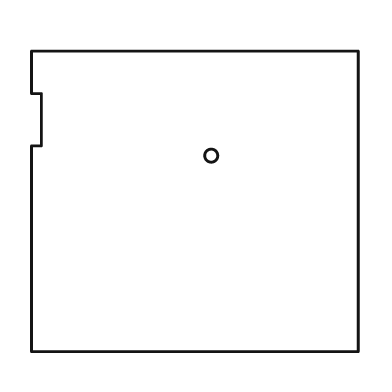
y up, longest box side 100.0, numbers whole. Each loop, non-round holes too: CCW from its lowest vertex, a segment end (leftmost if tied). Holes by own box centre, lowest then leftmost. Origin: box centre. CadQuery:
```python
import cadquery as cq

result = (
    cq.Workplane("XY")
    .moveTo(-50.0, -46.0)
    .lineTo(50.0, -46.0)
    .lineTo(50.0, 46.0)
    .lineTo(-50.0, 46.0)
    .lineTo(-50.0, 33.0)
    .lineTo(-47.0, 33.0)
    .lineTo(-47.0, 17.0)
    .lineTo(-50.0, 17.0)
    .close()
    .moveTo(5.0, 14.0)
    .circle(2.0)
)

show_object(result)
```